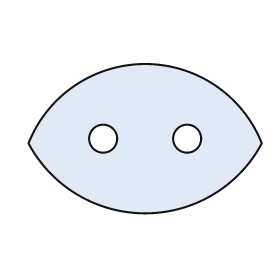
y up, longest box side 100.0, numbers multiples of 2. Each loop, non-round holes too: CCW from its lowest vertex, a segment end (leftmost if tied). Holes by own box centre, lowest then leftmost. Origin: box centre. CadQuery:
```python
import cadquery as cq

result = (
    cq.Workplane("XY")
    .moveTo(-50.0, -2.0)
    .threePointArc((0.0, -32.0), (50.0, -2.0))
    .threePointArc((0.0, 32.0), (-50.0, -2.0))
    .close()
    .moveTo(-18.0, 0.0)
    .circle(6.0)
    .moveTo(18.0, 0.0)
    .circle(6.0)
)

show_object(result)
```